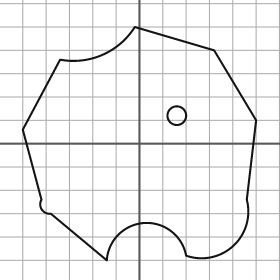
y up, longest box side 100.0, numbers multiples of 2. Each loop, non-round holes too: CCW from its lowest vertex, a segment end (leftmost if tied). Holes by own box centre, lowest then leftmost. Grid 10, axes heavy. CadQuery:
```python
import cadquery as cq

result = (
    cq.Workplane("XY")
    .moveTo(-14.0, -50.0)
    .threePointArc((2.0, -34.0), (20.0, -48.0))
    .threePointArc((40.0, -44.0), (46.0, -24.0))
    .lineTo(50.0, 10.0)
    .lineTo(32.0, 40.0)
    .lineTo(-2.0, 50.0)
    .threePointArc((-16.0, 38.0), (-34.0, 36.0))
    .lineTo(-50.0, 6.0)
    .lineTo(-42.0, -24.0)
    .threePointArc((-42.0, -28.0), (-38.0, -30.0))
    .close()
    .moveTo(16.0, 12.0)
    .circle(4.0)
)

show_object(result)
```